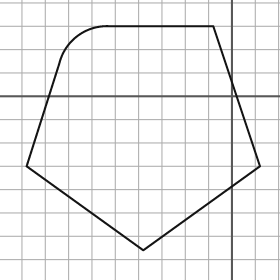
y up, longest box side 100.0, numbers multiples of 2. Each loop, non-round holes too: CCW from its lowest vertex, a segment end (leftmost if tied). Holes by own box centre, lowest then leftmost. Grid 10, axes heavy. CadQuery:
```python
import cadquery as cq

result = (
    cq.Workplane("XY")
    .moveTo(-38.0, -66.0)
    .lineTo(12.0, -30.0)
    .lineTo(-8.0, 30.0)
    .lineTo(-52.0, 30.0)
    .threePointArc((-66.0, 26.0), (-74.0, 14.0))
    .lineTo(-88.0, -30.0)
    .close()
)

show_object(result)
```